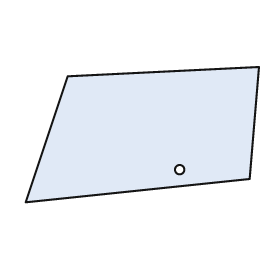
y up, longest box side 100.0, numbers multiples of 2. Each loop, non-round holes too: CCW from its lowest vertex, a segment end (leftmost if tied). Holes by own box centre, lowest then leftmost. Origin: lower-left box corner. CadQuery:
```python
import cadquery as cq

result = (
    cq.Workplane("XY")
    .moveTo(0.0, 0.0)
    .lineTo(96.0, 10.0)
    .lineTo(100.0, 58.0)
    .lineTo(18.0, 54.0)
    .close()
    .moveTo(66.0, 14.0)
    .circle(2.0)
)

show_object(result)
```